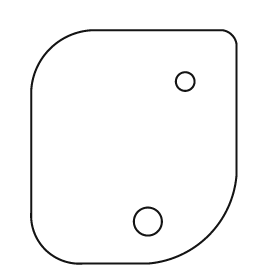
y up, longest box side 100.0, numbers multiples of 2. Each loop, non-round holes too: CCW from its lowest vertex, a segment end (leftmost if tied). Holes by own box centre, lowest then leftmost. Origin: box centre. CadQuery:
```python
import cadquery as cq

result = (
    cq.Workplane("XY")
    .moveTo(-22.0, -50.0)
    .lineTo(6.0, -50.0)
    .threePointArc((32.0, -38.0), (44.0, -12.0))
    .lineTo(44.0, 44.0)
    .threePointArc((42.0, 48.0), (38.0, 50.0))
    .lineTo(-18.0, 50.0)
    .threePointArc((-36.0, 42.0), (-44.0, 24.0))
    .lineTo(-44.0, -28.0)
    .threePointArc((-38.0, -44.0), (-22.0, -50.0))
    .close()
    .moveTo(6.0, -32.0)
    .circle(6.0)
    .moveTo(22.0, 28.0)
    .circle(4.0)
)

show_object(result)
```